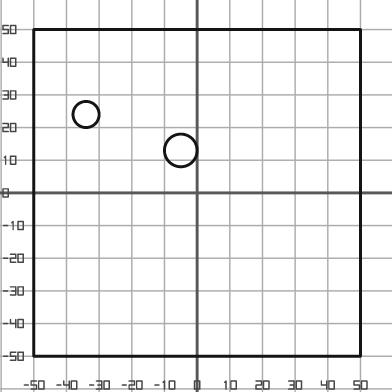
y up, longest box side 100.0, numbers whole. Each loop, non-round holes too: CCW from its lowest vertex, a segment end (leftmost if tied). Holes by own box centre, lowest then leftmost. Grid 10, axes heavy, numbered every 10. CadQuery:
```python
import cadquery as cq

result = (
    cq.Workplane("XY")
    .moveTo(-50.0, -50.0)
    .lineTo(50.0, -50.0)
    .lineTo(50.0, 50.0)
    .lineTo(-50.0, 50.0)
    .close()
    .moveTo(-5.0, 13.0)
    .circle(5.0)
    .moveTo(-34.0, 24.0)
    .circle(4.0)
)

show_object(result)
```